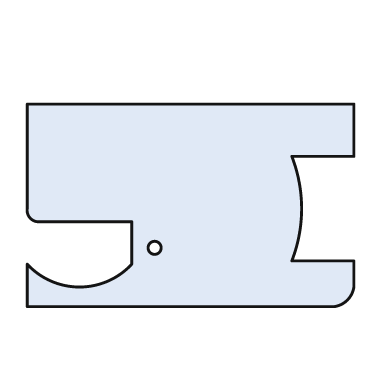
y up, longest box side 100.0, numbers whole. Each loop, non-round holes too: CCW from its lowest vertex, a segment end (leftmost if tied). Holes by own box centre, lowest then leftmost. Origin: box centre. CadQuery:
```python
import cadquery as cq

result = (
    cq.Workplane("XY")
    .moveTo(-50.0, -31.0)
    .lineTo(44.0, -31.0)
    .threePointArc((48.0, -29.0), (50.0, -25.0))
    .lineTo(50.0, -17.0)
    .lineTo(31.0, -17.0)
    .threePointArc((34.0, -1.0), (31.0, 15.0))
    .lineTo(50.0, 15.0)
    .lineTo(50.0, 31.0)
    .lineTo(-50.0, 31.0)
    .lineTo(-50.0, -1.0)
    .threePointArc((-49.0, -4.0), (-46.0, -5.0))
    .lineTo(-18.0, -5.0)
    .lineTo(-18.0, -18.0)
    .threePointArc((-34.0, -25.0), (-50.0, -18.0))
    .close()
    .moveTo(-11.0, -13.0)
    .circle(2.0)
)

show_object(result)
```